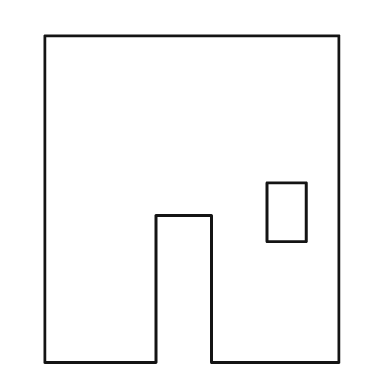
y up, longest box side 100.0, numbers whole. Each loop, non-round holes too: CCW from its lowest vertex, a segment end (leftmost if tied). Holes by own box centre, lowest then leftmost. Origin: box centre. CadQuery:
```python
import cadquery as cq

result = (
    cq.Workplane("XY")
    .moveTo(-45.0, -50.0)
    .lineTo(-11.0, -50.0)
    .lineTo(-11.0, -5.0)
    .lineTo(6.0, -5.0)
    .lineTo(6.0, -50.0)
    .lineTo(45.0, -50.0)
    .lineTo(45.0, 50.0)
    .lineTo(-45.0, 50.0)
    .close()
    .moveTo(23.0, -13.0)
    .lineTo(35.0, -13.0)
    .lineTo(35.0, 5.0)
    .lineTo(23.0, 5.0)
    .close()
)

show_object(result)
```